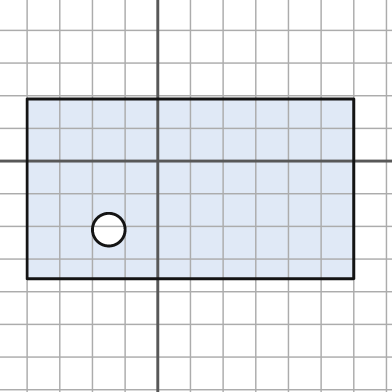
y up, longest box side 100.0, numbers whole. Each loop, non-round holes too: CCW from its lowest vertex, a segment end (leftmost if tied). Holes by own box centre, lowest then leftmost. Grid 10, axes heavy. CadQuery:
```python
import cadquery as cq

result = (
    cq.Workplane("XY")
    .moveTo(-40.0, -36.0)
    .lineTo(60.0, -36.0)
    .lineTo(60.0, 19.0)
    .lineTo(-40.0, 19.0)
    .close()
    .moveTo(-15.0, -21.0)
    .circle(5.0)
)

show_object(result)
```